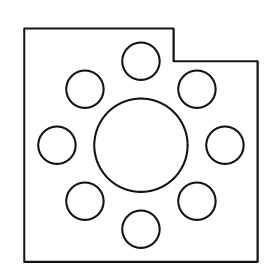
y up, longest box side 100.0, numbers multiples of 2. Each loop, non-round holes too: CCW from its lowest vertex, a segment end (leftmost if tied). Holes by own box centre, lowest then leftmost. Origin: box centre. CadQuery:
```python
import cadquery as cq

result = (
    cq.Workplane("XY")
    .moveTo(-50.0, -50.0)
    .lineTo(50.0, -50.0)
    .lineTo(50.0, 36.0)
    .lineTo(14.0, 36.0)
    .lineTo(14.0, 50.0)
    .lineTo(-50.0, 50.0)
    .close()
    .moveTo(0.0, -36.0)
    .circle(8.0)
    .moveTo(-24.0, -24.0)
    .circle(8.0)
    .moveTo(24.0, -24.0)
    .circle(8.0)
    .moveTo(-36.0, 0.0)
    .circle(8.0)
    .moveTo(0.0, 0.0)
    .circle(20.0)
    .moveTo(36.0, 0.0)
    .circle(8.0)
    .moveTo(-24.0, 24.0)
    .circle(8.0)
    .moveTo(24.0, 24.0)
    .circle(8.0)
    .moveTo(0.0, 36.0)
    .circle(8.0)
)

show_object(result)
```